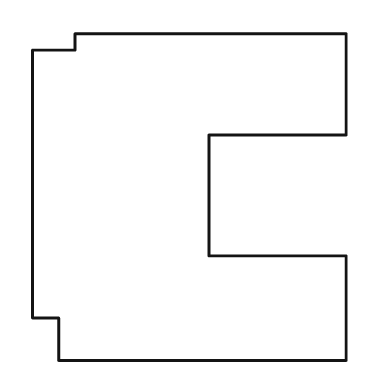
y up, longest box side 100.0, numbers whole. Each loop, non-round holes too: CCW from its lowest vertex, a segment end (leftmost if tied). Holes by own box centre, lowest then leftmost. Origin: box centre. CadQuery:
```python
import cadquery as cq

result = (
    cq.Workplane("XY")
    .moveTo(-40.0, -50.0)
    .lineTo(48.0, -50.0)
    .lineTo(48.0, -18.0)
    .lineTo(6.0, -18.0)
    .lineTo(6.0, 19.0)
    .lineTo(48.0, 19.0)
    .lineTo(48.0, 50.0)
    .lineTo(-35.0, 50.0)
    .lineTo(-35.0, 45.0)
    .lineTo(-48.0, 45.0)
    .lineTo(-48.0, -37.0)
    .lineTo(-40.0, -37.0)
    .close()
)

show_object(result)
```